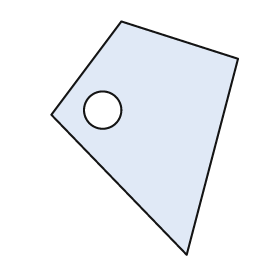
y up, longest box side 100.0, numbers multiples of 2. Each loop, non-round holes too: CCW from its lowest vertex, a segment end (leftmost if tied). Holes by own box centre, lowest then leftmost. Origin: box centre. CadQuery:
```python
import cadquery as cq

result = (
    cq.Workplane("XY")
    .moveTo(18.0, -50.0)
    .lineTo(40.0, 34.0)
    .lineTo(-10.0, 50.0)
    .lineTo(-40.0, 10.0)
    .close()
    .moveTo(-18.0, 12.0)
    .circle(8.0)
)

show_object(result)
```